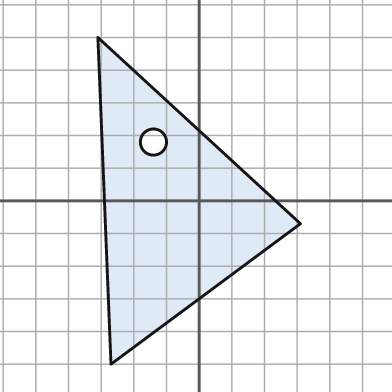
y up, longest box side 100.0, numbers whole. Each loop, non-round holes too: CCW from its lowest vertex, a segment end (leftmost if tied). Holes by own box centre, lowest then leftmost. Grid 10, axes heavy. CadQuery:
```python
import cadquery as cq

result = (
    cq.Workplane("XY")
    .moveTo(-27.0, -50.0)
    .lineTo(31.0, -7.0)
    .lineTo(-31.0, 50.0)
    .close()
    .moveTo(-14.0, 18.0)
    .circle(4.0)
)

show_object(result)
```